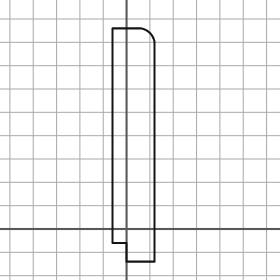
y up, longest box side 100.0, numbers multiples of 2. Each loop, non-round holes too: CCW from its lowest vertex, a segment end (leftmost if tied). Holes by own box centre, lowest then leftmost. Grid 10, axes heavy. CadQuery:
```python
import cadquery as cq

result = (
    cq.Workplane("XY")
    .moveTo(0.0, -14.0)
    .lineTo(12.0, -14.0)
    .lineTo(12.0, 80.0)
    .threePointArc((10.0, 84.0), (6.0, 86.0))
    .lineTo(-6.0, 86.0)
    .lineTo(-6.0, -6.0)
    .lineTo(0.0, -6.0)
    .close()
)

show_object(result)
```